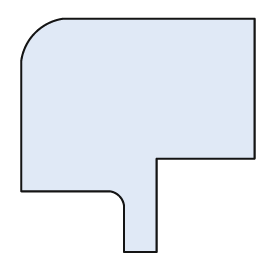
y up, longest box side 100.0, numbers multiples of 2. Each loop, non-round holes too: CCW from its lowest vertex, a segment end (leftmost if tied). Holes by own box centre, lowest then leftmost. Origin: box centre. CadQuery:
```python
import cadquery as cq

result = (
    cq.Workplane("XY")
    .moveTo(-6.0, -50.0)
    .lineTo(8.0, -50.0)
    .lineTo(8.0, -10.0)
    .lineTo(50.0, -10.0)
    .lineTo(50.0, 50.0)
    .lineTo(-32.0, 50.0)
    .threePointArc((-44.0, 44.0), (-50.0, 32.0))
    .lineTo(-50.0, -24.0)
    .lineTo(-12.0, -24.0)
    .threePointArc((-8.0, -26.0), (-6.0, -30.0))
    .close()
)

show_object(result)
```